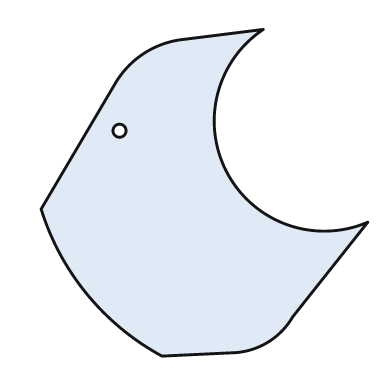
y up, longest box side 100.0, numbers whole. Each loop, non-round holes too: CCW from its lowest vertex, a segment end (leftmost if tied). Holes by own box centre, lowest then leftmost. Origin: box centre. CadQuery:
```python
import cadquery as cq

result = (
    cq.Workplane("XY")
    .moveTo(-13.0, -50.0)
    .lineTo(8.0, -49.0)
    .threePointArc((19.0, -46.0), (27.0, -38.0))
    .lineTo(50.0, -9.0)
    .threePointArc((7.0, 6.0), (18.0, 50.0))
    .lineTo(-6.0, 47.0)
    .threePointArc((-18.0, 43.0), (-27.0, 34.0))
    .lineTo(-50.0, -5.0)
    .threePointArc((-36.0, -31.0), (-13.0, -50.0))
    .close()
    .moveTo(-26.0, 19.0)
    .circle(2.0)
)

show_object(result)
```